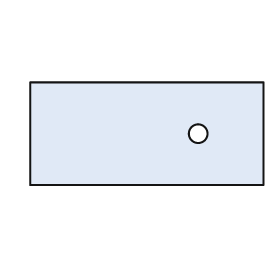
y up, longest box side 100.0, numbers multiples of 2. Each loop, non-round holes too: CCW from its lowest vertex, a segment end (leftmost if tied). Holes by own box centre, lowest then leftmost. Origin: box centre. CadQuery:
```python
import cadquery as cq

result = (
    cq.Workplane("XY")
    .moveTo(-50.0, -22.0)
    .lineTo(50.0, -22.0)
    .lineTo(50.0, 22.0)
    .lineTo(-50.0, 22.0)
    .close()
    .moveTo(22.0, 0.0)
    .circle(4.0)
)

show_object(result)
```